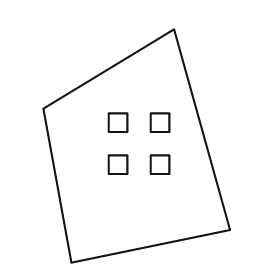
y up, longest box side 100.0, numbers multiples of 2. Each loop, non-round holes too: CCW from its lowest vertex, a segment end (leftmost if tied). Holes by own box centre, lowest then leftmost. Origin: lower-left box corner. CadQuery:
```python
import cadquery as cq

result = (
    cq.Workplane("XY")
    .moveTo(12.0, 0.0)
    .lineTo(80.0, 14.0)
    .lineTo(56.0, 100.0)
    .lineTo(0.0, 66.0)
    .close()
    .moveTo(28.0, 38.0)
    .lineTo(36.0, 38.0)
    .lineTo(36.0, 46.0)
    .lineTo(28.0, 46.0)
    .close()
    .moveTo(46.0, 38.0)
    .lineTo(54.0, 38.0)
    .lineTo(54.0, 46.0)
    .lineTo(46.0, 46.0)
    .close()
    .moveTo(28.0, 56.0)
    .lineTo(36.0, 56.0)
    .lineTo(36.0, 64.0)
    .lineTo(28.0, 64.0)
    .close()
    .moveTo(46.0, 56.0)
    .lineTo(54.0, 56.0)
    .lineTo(54.0, 64.0)
    .lineTo(46.0, 64.0)
    .close()
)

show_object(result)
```